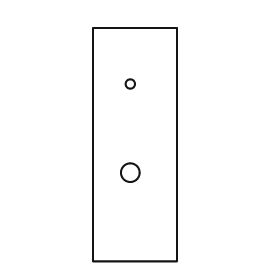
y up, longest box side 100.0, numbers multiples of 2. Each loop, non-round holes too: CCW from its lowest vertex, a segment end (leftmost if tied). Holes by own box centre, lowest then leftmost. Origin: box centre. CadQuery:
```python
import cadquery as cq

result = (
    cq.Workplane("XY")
    .moveTo(-18.0, -50.0)
    .lineTo(18.0, -50.0)
    .lineTo(18.0, 50.0)
    .lineTo(-18.0, 50.0)
    .close()
    .moveTo(-2.0, -12.0)
    .circle(4.0)
    .moveTo(-2.0, 26.0)
    .circle(2.0)
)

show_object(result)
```